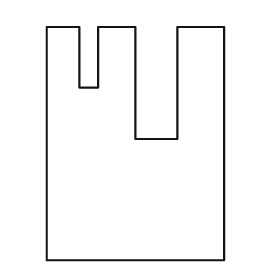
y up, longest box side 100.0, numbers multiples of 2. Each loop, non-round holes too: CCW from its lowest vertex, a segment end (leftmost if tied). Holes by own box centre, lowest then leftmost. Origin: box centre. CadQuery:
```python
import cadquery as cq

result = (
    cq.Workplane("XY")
    .moveTo(-38.0, -50.0)
    .lineTo(38.0, -50.0)
    .lineTo(38.0, 50.0)
    .lineTo(18.0, 50.0)
    .lineTo(18.0, 2.0)
    .lineTo(0.0, 2.0)
    .lineTo(0.0, 50.0)
    .lineTo(-16.0, 50.0)
    .lineTo(-16.0, 24.0)
    .lineTo(-24.0, 24.0)
    .lineTo(-24.0, 50.0)
    .lineTo(-38.0, 50.0)
    .close()
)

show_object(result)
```